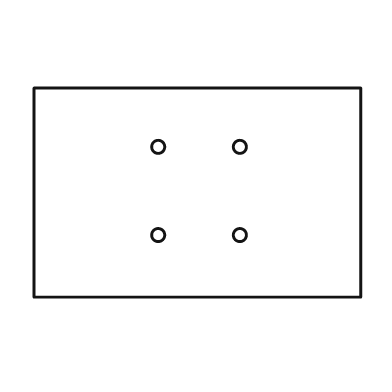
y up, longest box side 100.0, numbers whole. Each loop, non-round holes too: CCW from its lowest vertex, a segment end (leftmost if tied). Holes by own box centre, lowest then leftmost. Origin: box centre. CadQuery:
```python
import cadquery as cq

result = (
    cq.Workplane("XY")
    .moveTo(-50.0, -32.0)
    .lineTo(50.0, -32.0)
    .lineTo(50.0, 32.0)
    .lineTo(-50.0, 32.0)
    .close()
    .moveTo(-12.0, -13.0)
    .circle(2.0)
    .moveTo(13.0, -13.0)
    .circle(2.0)
    .moveTo(-12.0, 14.0)
    .circle(2.0)
    .moveTo(13.0, 14.0)
    .circle(2.0)
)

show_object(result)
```